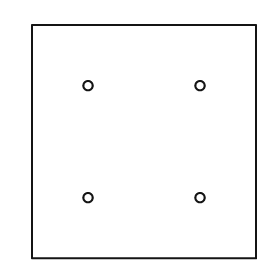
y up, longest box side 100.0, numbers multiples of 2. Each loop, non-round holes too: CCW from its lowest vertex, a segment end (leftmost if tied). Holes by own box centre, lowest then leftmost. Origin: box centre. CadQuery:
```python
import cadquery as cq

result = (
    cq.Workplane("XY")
    .moveTo(-48.0, -50.0)
    .lineTo(48.0, -50.0)
    .lineTo(48.0, 50.0)
    .lineTo(-48.0, 50.0)
    .close()
    .moveTo(-24.0, -24.0)
    .circle(2.0)
    .moveTo(24.0, -24.0)
    .circle(2.0)
    .moveTo(-24.0, 24.0)
    .circle(2.0)
    .moveTo(24.0, 24.0)
    .circle(2.0)
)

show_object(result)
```